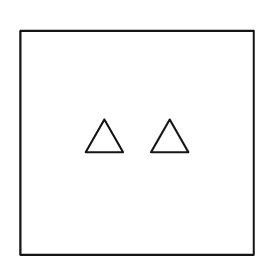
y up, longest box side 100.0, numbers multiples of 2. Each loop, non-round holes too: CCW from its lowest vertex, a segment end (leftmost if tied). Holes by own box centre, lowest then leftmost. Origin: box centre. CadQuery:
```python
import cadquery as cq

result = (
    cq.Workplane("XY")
    .moveTo(-50.0, -48.0)
    .lineTo(50.0, -48.0)
    .lineTo(50.0, 48.0)
    .lineTo(-50.0, 48.0)
    .close()
    .moveTo(-22.0, -4.0)
    .lineTo(-6.0, -4.0)
    .lineTo(-14.0, 10.0)
    .close()
    .moveTo(6.0, -4.0)
    .lineTo(22.0, -4.0)
    .lineTo(14.0, 10.0)
    .close()
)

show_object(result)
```